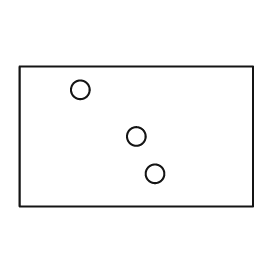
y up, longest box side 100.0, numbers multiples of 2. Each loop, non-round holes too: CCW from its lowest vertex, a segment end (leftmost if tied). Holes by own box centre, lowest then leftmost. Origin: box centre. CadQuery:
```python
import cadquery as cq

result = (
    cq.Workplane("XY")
    .moveTo(-50.0, -30.0)
    .lineTo(50.0, -30.0)
    .lineTo(50.0, 30.0)
    .lineTo(-50.0, 30.0)
    .close()
    .moveTo(8.0, -16.0)
    .circle(4.0)
    .moveTo(0.0, 0.0)
    .circle(4.0)
    .moveTo(-24.0, 20.0)
    .circle(4.0)
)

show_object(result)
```